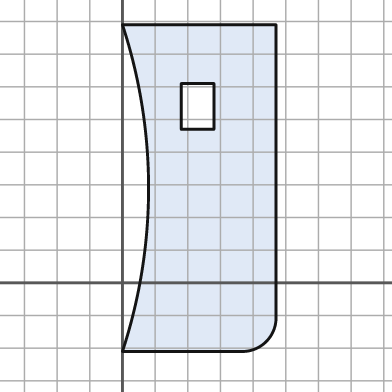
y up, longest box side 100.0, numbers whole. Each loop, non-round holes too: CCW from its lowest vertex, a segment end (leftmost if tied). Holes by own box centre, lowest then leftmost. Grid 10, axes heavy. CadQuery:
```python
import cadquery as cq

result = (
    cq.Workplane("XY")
    .moveTo(0.0, -21.0)
    .lineTo(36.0, -21.0)
    .threePointArc((44.0, -18.0), (47.0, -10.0))
    .lineTo(47.0, 79.0)
    .lineTo(0.0, 79.0)
    .threePointArc((8.0, 29.0), (0.0, -21.0))
    .close()
    .moveTo(18.0, 47.0)
    .lineTo(28.0, 47.0)
    .lineTo(28.0, 61.0)
    .lineTo(18.0, 61.0)
    .close()
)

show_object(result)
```